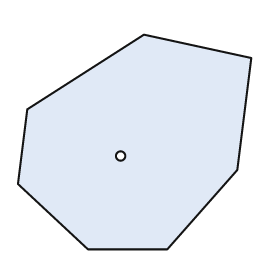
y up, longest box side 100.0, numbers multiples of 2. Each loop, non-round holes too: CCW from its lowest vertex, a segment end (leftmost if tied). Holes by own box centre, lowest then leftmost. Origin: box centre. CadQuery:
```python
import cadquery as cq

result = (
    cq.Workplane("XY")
    .moveTo(-20.0, -46.0)
    .lineTo(14.0, -46.0)
    .lineTo(44.0, -12.0)
    .lineTo(50.0, 36.0)
    .lineTo(4.0, 46.0)
    .lineTo(-46.0, 14.0)
    .lineTo(-50.0, -18.0)
    .close()
    .moveTo(-6.0, -6.0)
    .circle(2.0)
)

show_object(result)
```